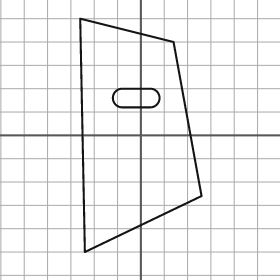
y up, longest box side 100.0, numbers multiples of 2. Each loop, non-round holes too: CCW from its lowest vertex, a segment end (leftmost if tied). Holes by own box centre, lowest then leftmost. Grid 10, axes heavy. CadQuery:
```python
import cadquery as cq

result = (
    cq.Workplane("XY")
    .moveTo(-24.0, -50.0)
    .lineTo(26.0, -26.0)
    .lineTo(14.0, 40.0)
    .lineTo(-26.0, 50.0)
    .close()
    .moveTo(-8.0, 12.0)
    .lineTo(4.0, 12.0)
    .threePointArc((8.0, 16.0), (4.0, 20.0))
    .lineTo(-8.0, 20.0)
    .threePointArc((-12.0, 16.0), (-8.0, 12.0))
    .close()
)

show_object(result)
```